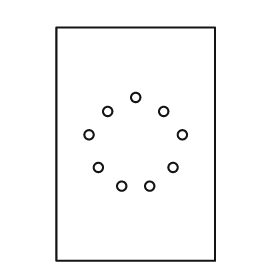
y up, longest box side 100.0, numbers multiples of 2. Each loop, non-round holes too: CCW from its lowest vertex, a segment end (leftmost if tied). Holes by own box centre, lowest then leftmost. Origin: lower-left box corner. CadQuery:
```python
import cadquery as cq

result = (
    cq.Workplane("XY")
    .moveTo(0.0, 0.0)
    .lineTo(68.0, 0.0)
    .lineTo(68.0, 100.0)
    .lineTo(0.0, 100.0)
    .close()
    .moveTo(28.0, 32.0)
    .circle(2.0)
    .moveTo(40.0, 32.0)
    .circle(2.0)
    .moveTo(18.0, 40.0)
    .circle(2.0)
    .moveTo(50.0, 40.0)
    .circle(2.0)
    .moveTo(14.0, 54.0)
    .circle(2.0)
    .moveTo(54.0, 54.0)
    .circle(2.0)
    .moveTo(22.0, 64.0)
    .circle(2.0)
    .moveTo(46.0, 64.0)
    .circle(2.0)
    .moveTo(34.0, 70.0)
    .circle(2.0)
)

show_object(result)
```